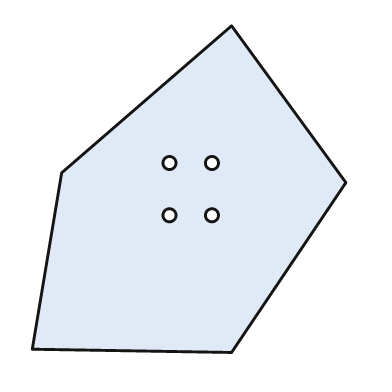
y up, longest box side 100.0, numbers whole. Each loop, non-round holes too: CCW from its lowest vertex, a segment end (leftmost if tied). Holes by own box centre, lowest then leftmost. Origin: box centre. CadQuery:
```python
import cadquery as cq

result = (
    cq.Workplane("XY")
    .moveTo(13.0, -50.0)
    .lineTo(48.0, 2.0)
    .lineTo(13.0, 50.0)
    .lineTo(-39.0, 5.0)
    .lineTo(-48.0, -49.0)
    .close()
    .moveTo(-6.0, -8.0)
    .circle(2.0)
    .moveTo(7.0, -8.0)
    .circle(2.0)
    .moveTo(-6.0, 8.0)
    .circle(2.0)
    .moveTo(7.0, 8.0)
    .circle(2.0)
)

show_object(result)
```